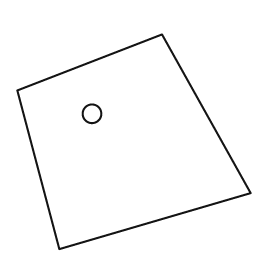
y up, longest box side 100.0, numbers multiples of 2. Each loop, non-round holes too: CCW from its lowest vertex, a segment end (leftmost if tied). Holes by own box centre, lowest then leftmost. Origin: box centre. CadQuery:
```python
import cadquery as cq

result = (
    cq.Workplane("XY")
    .moveTo(-32.0, -46.0)
    .lineTo(50.0, -22.0)
    .lineTo(12.0, 46.0)
    .lineTo(-50.0, 22.0)
    .close()
    .moveTo(-18.0, 12.0)
    .circle(4.0)
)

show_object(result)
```